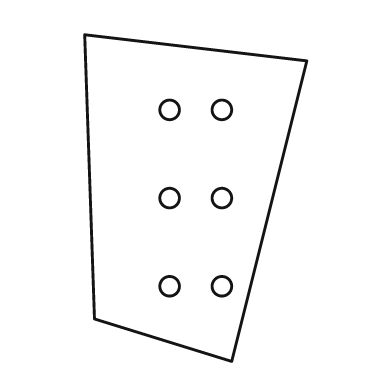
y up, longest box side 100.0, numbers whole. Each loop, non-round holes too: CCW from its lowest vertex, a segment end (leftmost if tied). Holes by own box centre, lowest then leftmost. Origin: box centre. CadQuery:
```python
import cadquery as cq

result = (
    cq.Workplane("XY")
    .moveTo(11.0, -50.0)
    .lineTo(34.0, 42.0)
    .lineTo(-34.0, 50.0)
    .lineTo(-31.0, -37.0)
    .close()
    .moveTo(-8.0, -27.0)
    .circle(3.0)
    .moveTo(8.0, -27.0)
    .circle(3.0)
    .moveTo(-8.0, 0.0)
    .circle(3.0)
    .moveTo(8.0, 0.0)
    .circle(3.0)
    .moveTo(-8.0, 27.0)
    .circle(3.0)
    .moveTo(8.0, 27.0)
    .circle(3.0)
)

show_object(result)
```